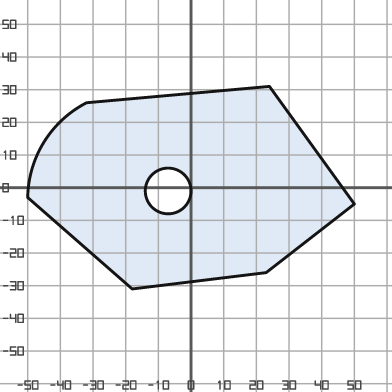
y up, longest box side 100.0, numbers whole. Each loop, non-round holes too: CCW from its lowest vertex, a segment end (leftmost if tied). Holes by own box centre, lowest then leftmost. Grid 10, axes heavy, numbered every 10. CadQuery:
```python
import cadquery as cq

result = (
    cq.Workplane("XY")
    .moveTo(-18.0, -31.0)
    .lineTo(23.0, -26.0)
    .lineTo(50.0, -5.0)
    .lineTo(24.0, 31.0)
    .lineTo(-32.0, 26.0)
    .threePointArc((-45.0, 14.0), (-50.0, -3.0))
    .close()
    .moveTo(-7.0, -1.0)
    .circle(7.0)
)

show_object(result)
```